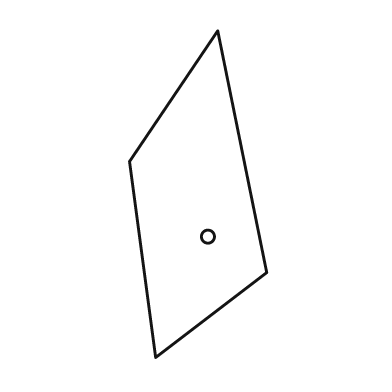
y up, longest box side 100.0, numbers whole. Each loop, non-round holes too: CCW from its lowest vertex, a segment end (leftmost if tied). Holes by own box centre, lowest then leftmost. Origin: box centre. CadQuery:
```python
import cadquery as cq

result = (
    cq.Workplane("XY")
    .moveTo(-13.0, -50.0)
    .lineTo(21.0, -24.0)
    .lineTo(6.0, 50.0)
    .lineTo(-21.0, 10.0)
    .close()
    .moveTo(3.0, -13.0)
    .circle(2.0)
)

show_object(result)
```